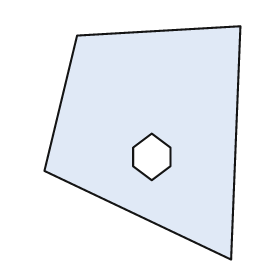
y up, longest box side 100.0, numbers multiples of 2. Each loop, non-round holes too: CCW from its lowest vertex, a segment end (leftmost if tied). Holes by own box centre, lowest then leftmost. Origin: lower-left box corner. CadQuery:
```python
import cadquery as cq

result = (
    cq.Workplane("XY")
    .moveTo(80.0, 0.0)
    .lineTo(84.0, 100.0)
    .lineTo(14.0, 96.0)
    .lineTo(0.0, 38.0)
    .close()
    .moveTo(46.0, 34.0)
    .lineTo(54.0, 40.0)
    .lineTo(54.0, 48.0)
    .lineTo(46.0, 54.0)
    .lineTo(38.0, 48.0)
    .lineTo(38.0, 40.0)
    .close()
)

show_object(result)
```